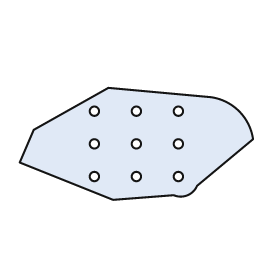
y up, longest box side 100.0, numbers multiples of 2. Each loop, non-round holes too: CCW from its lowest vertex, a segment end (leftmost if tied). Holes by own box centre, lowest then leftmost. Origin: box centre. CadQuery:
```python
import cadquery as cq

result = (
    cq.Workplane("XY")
    .moveTo(-10.0, -24.0)
    .lineTo(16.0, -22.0)
    .threePointArc((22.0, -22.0), (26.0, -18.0))
    .lineTo(50.0, 2.0)
    .threePointArc((44.0, 14.0), (32.0, 20.0))
    .lineTo(-12.0, 24.0)
    .lineTo(-44.0, 6.0)
    .lineTo(-50.0, -8.0)
    .close()
    .moveTo(-18.0, -14.0)
    .circle(2.0)
    .moveTo(0.0, -14.0)
    .circle(2.0)
    .moveTo(18.0, -14.0)
    .circle(2.0)
    .moveTo(-18.0, 0.0)
    .circle(2.0)
    .moveTo(0.0, 0.0)
    .circle(2.0)
    .moveTo(18.0, 0.0)
    .circle(2.0)
    .moveTo(-18.0, 14.0)
    .circle(2.0)
    .moveTo(0.0, 14.0)
    .circle(2.0)
    .moveTo(18.0, 14.0)
    .circle(2.0)
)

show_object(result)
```